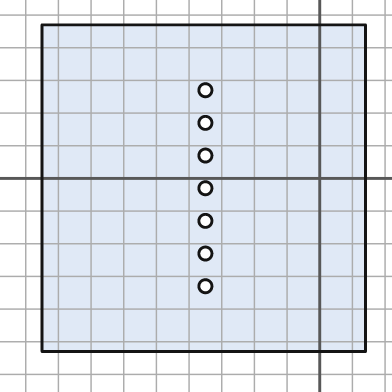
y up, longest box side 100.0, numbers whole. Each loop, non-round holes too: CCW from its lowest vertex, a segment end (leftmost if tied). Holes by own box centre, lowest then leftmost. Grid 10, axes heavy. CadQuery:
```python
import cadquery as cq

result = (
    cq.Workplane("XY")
    .moveTo(-85.0, -53.0)
    .lineTo(14.0, -53.0)
    .lineTo(14.0, 47.0)
    .lineTo(-85.0, 47.0)
    .close()
    .moveTo(-35.0, -33.0)
    .circle(2.0)
    .moveTo(-35.0, -23.0)
    .circle(2.0)
    .moveTo(-35.0, -13.0)
    .circle(2.0)
    .moveTo(-35.0, -3.0)
    .circle(2.0)
    .moveTo(-35.0, 7.0)
    .circle(2.0)
    .moveTo(-35.0, 17.0)
    .circle(2.0)
    .moveTo(-35.0, 27.0)
    .circle(2.0)
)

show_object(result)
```